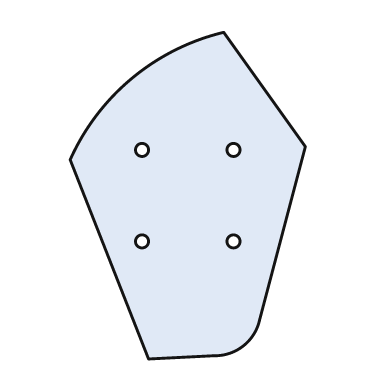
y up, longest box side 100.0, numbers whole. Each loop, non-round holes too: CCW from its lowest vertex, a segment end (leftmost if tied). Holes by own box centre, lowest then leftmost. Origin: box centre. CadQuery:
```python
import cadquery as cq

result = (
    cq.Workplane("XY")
    .moveTo(-12.0, -50.0)
    .lineTo(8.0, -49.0)
    .threePointArc((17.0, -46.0), (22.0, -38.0))
    .lineTo(36.0, 15.0)
    .lineTo(11.0, 50.0)
    .threePointArc((-17.0, 36.0), (-36.0, 11.0))
    .close()
    .moveTo(-14.0, -14.0)
    .circle(2.0)
    .moveTo(14.0, -14.0)
    .circle(2.0)
    .moveTo(-14.0, 14.0)
    .circle(2.0)
    .moveTo(14.0, 14.0)
    .circle(2.0)
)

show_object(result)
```